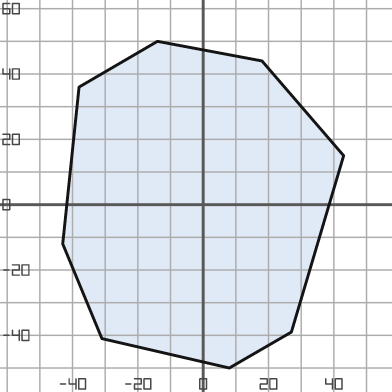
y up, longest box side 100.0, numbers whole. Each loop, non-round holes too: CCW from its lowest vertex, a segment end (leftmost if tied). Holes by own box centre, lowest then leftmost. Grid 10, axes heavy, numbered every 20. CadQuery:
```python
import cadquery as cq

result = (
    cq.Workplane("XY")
    .moveTo(8.0, -50.0)
    .lineTo(27.0, -39.0)
    .lineTo(43.0, 15.0)
    .lineTo(18.0, 44.0)
    .lineTo(-14.0, 50.0)
    .lineTo(-38.0, 36.0)
    .lineTo(-43.0, -12.0)
    .lineTo(-31.0, -41.0)
    .close()
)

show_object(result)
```